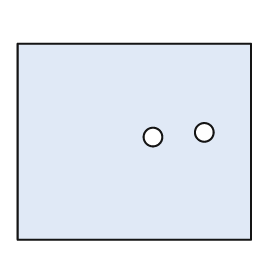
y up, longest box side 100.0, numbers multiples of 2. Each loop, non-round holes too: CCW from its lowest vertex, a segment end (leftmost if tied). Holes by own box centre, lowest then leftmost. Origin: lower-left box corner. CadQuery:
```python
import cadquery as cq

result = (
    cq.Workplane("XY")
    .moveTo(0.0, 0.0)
    .lineTo(100.0, 0.0)
    .lineTo(100.0, 84.0)
    .lineTo(0.0, 84.0)
    .close()
    .moveTo(58.0, 44.0)
    .circle(4.0)
    .moveTo(80.0, 46.0)
    .circle(4.0)
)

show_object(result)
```